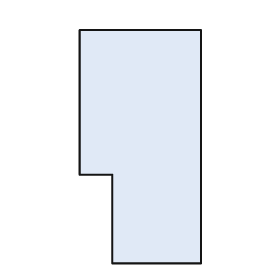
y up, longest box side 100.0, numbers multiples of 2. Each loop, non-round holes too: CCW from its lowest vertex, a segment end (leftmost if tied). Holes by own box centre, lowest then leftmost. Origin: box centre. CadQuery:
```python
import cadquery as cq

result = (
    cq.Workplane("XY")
    .moveTo(-12.0, -50.0)
    .lineTo(26.0, -50.0)
    .lineTo(26.0, 50.0)
    .lineTo(-26.0, 50.0)
    .lineTo(-26.0, -12.0)
    .lineTo(-12.0, -12.0)
    .close()
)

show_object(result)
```